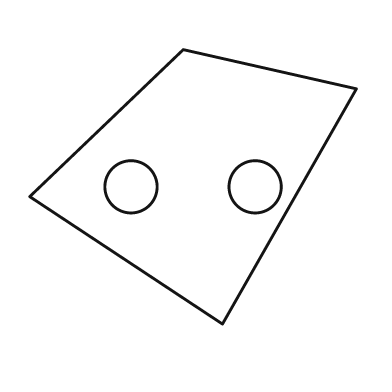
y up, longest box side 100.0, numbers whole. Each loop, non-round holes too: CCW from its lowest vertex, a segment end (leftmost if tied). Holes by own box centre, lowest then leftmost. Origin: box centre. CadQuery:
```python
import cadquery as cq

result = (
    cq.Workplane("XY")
    .moveTo(9.0, -42.0)
    .lineTo(50.0, 30.0)
    .lineTo(-3.0, 42.0)
    .lineTo(-50.0, -3.0)
    .close()
    .moveTo(-19.0, 0.0)
    .circle(8.0)
    .moveTo(19.0, 0.0)
    .circle(8.0)
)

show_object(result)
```